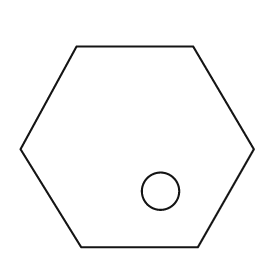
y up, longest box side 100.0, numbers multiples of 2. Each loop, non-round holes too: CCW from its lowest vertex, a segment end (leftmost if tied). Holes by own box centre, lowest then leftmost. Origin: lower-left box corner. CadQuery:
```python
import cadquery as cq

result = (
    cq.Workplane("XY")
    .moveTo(26.0, 0.0)
    .lineTo(76.0, 0.0)
    .lineTo(100.0, 42.0)
    .lineTo(74.0, 86.0)
    .lineTo(24.0, 86.0)
    .lineTo(0.0, 42.0)
    .close()
    .moveTo(60.0, 24.0)
    .circle(8.0)
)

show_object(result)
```